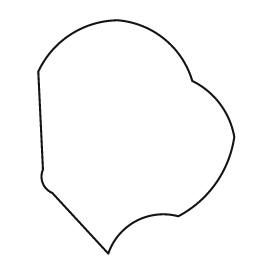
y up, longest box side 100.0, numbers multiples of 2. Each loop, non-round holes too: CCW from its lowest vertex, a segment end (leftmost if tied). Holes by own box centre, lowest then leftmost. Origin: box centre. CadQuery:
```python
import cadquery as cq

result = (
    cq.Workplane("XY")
    .moveTo(-12.0, -50.0)
    .threePointArc((0.0, -36.0), (18.0, -34.0))
    .threePointArc((34.0, -20.0), (42.0, 0.0))
    .threePointArc((36.0, 14.0), (24.0, 24.0))
    .threePointArc((12.0, 42.0), (-8.0, 50.0))
    .threePointArc((-28.0, 44.0), (-42.0, 28.0))
    .lineTo(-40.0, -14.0)
    .threePointArc((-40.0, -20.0), (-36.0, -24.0))
    .close()
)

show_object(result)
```